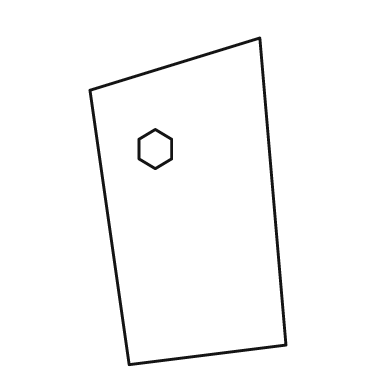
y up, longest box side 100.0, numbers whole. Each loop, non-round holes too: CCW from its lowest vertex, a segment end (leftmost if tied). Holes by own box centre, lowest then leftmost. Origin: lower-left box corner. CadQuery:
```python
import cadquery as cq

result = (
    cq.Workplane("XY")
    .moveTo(12.0, 0.0)
    .lineTo(60.0, 6.0)
    .lineTo(52.0, 100.0)
    .lineTo(0.0, 84.0)
    .close()
    .moveTo(20.0, 60.0)
    .lineTo(25.0, 63.0)
    .lineTo(25.0, 69.0)
    .lineTo(20.0, 72.0)
    .lineTo(15.0, 69.0)
    .lineTo(15.0, 63.0)
    .close()
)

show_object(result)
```